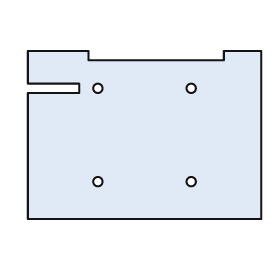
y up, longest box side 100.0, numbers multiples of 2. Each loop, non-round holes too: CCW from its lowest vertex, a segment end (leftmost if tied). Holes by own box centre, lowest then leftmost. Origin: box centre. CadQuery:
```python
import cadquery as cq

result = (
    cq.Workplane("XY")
    .moveTo(-50.0, -36.0)
    .lineTo(50.0, -36.0)
    .lineTo(50.0, 36.0)
    .lineTo(34.0, 36.0)
    .lineTo(34.0, 32.0)
    .lineTo(-24.0, 32.0)
    .lineTo(-24.0, 36.0)
    .lineTo(-50.0, 36.0)
    .lineTo(-50.0, 22.0)
    .lineTo(-28.0, 22.0)
    .lineTo(-28.0, 18.0)
    .lineTo(-50.0, 18.0)
    .close()
    .moveTo(-20.0, -20.0)
    .circle(2.0)
    .moveTo(20.0, -20.0)
    .circle(2.0)
    .moveTo(-20.0, 20.0)
    .circle(2.0)
    .moveTo(20.0, 20.0)
    .circle(2.0)
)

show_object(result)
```